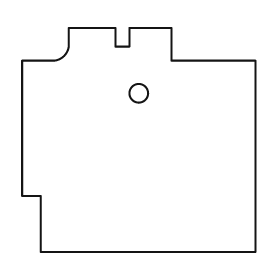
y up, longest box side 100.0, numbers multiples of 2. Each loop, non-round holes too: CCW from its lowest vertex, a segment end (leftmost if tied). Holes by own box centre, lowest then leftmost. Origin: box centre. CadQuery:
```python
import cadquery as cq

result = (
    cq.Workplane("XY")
    .moveTo(-42.0, -48.0)
    .lineTo(50.0, -48.0)
    .lineTo(50.0, 34.0)
    .lineTo(14.0, 34.0)
    .lineTo(14.0, 48.0)
    .lineTo(-4.0, 48.0)
    .lineTo(-4.0, 40.0)
    .lineTo(-10.0, 40.0)
    .lineTo(-10.0, 48.0)
    .lineTo(-30.0, 48.0)
    .lineTo(-30.0, 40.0)
    .threePointArc((-32.0, 36.0), (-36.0, 34.0))
    .lineTo(-50.0, 34.0)
    .lineTo(-50.0, -24.0)
    .lineTo(-42.0, -24.0)
    .close()
    .moveTo(0.0, 20.0)
    .circle(4.0)
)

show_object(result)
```